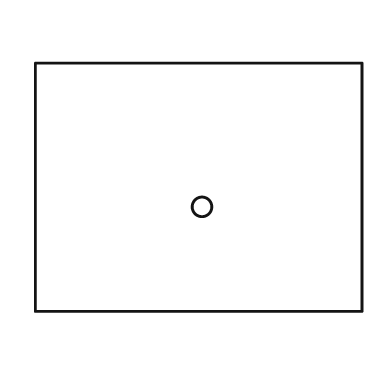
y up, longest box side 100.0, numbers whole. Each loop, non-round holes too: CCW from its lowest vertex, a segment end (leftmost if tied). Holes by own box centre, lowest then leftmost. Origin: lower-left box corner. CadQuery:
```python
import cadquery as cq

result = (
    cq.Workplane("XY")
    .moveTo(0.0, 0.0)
    .lineTo(100.0, 0.0)
    .lineTo(100.0, 76.0)
    .lineTo(0.0, 76.0)
    .close()
    .moveTo(51.0, 32.0)
    .circle(3.0)
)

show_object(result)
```